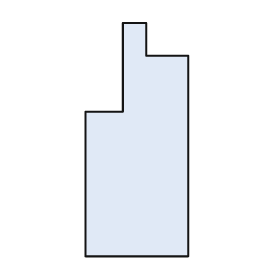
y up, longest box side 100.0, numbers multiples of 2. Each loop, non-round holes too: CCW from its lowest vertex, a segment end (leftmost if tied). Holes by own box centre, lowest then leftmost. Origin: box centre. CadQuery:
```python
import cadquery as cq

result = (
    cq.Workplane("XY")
    .moveTo(-22.0, -50.0)
    .lineTo(22.0, -50.0)
    .lineTo(22.0, 36.0)
    .lineTo(4.0, 36.0)
    .lineTo(4.0, 50.0)
    .lineTo(-6.0, 50.0)
    .lineTo(-6.0, 12.0)
    .lineTo(-22.0, 12.0)
    .close()
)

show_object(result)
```